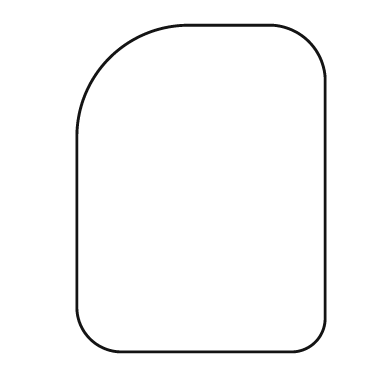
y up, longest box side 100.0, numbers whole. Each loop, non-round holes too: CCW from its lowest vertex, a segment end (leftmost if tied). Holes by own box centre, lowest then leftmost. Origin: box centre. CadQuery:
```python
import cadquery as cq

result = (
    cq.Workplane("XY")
    .moveTo(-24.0, -50.0)
    .lineTo(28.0, -50.0)
    .threePointArc((35.0, -47.0), (38.0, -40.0))
    .lineTo(38.0, 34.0)
    .threePointArc((33.0, 45.0), (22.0, 50.0))
    .lineTo(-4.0, 50.0)
    .threePointArc((-28.0, 40.0), (-38.0, 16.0))
    .lineTo(-38.0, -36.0)
    .threePointArc((-34.0, -46.0), (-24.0, -50.0))
    .close()
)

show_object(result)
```